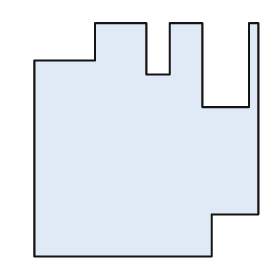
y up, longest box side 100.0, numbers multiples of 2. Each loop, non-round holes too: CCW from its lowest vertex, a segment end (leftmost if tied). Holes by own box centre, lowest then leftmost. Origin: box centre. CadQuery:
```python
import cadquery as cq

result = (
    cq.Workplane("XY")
    .moveTo(-48.0, -50.0)
    .lineTo(28.0, -50.0)
    .lineTo(28.0, -32.0)
    .lineTo(48.0, -32.0)
    .lineTo(48.0, 50.0)
    .lineTo(44.0, 50.0)
    .lineTo(44.0, 14.0)
    .lineTo(24.0, 14.0)
    .lineTo(24.0, 50.0)
    .lineTo(10.0, 50.0)
    .lineTo(10.0, 28.0)
    .lineTo(0.0, 28.0)
    .lineTo(0.0, 50.0)
    .lineTo(-22.0, 50.0)
    .lineTo(-22.0, 34.0)
    .lineTo(-48.0, 34.0)
    .close()
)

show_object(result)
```